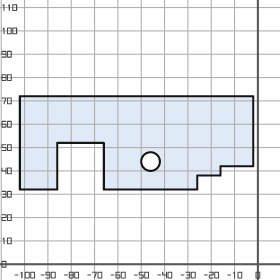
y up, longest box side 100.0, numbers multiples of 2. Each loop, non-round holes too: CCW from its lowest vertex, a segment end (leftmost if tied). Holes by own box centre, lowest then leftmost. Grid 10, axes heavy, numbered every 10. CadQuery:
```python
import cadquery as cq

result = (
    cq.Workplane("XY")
    .moveTo(-102.0, 32.0)
    .lineTo(-86.0, 32.0)
    .lineTo(-86.0, 52.0)
    .lineTo(-66.0, 52.0)
    .lineTo(-66.0, 32.0)
    .lineTo(-26.0, 32.0)
    .lineTo(-26.0, 38.0)
    .lineTo(-16.0, 38.0)
    .lineTo(-16.0, 42.0)
    .lineTo(-2.0, 42.0)
    .lineTo(-2.0, 72.0)
    .lineTo(-102.0, 72.0)
    .close()
    .moveTo(-46.0, 44.0)
    .circle(4.0)
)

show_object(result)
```